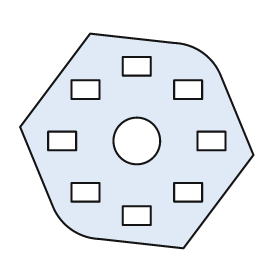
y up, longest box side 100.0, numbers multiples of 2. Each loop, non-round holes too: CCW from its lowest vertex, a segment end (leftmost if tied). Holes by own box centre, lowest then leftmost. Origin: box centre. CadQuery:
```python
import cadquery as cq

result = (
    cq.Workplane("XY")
    .moveTo(20.0, -46.0)
    .lineTo(50.0, -6.0)
    .lineTo(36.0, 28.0)
    .threePointArc((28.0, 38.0), (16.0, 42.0))
    .lineTo(-20.0, 46.0)
    .lineTo(-50.0, 6.0)
    .lineTo(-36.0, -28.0)
    .threePointArc((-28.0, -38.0), (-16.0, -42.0))
    .close()
    .moveTo(-6.0, -36.0)
    .lineTo(6.0, -36.0)
    .lineTo(6.0, -28.0)
    .lineTo(-6.0, -28.0)
    .close()
    .moveTo(-28.0, -26.0)
    .lineTo(-16.0, -26.0)
    .lineTo(-16.0, -18.0)
    .lineTo(-28.0, -18.0)
    .close()
    .moveTo(16.0, -26.0)
    .lineTo(28.0, -26.0)
    .lineTo(28.0, -18.0)
    .lineTo(16.0, -18.0)
    .close()
    .moveTo(-38.0, -4.0)
    .lineTo(-26.0, -4.0)
    .lineTo(-26.0, 4.0)
    .lineTo(-38.0, 4.0)
    .close()
    .moveTo(0.0, 0.0)
    .circle(10.0)
    .moveTo(26.0, -4.0)
    .lineTo(38.0, -4.0)
    .lineTo(38.0, 4.0)
    .lineTo(26.0, 4.0)
    .close()
    .moveTo(-28.0, 18.0)
    .lineTo(-16.0, 18.0)
    .lineTo(-16.0, 26.0)
    .lineTo(-28.0, 26.0)
    .close()
    .moveTo(16.0, 18.0)
    .lineTo(28.0, 18.0)
    .lineTo(28.0, 26.0)
    .lineTo(16.0, 26.0)
    .close()
    .moveTo(-6.0, 28.0)
    .lineTo(6.0, 28.0)
    .lineTo(6.0, 36.0)
    .lineTo(-6.0, 36.0)
    .close()
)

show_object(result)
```